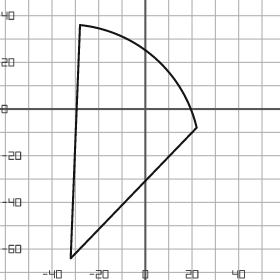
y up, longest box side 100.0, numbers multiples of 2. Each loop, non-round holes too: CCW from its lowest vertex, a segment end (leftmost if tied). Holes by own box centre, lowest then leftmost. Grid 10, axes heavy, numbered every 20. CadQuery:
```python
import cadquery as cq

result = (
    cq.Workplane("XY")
    .moveTo(-32.0, -64.0)
    .lineTo(22.0, -8.0)
    .threePointArc((4.0, 22.0), (-28.0, 36.0))
    .close()
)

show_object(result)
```